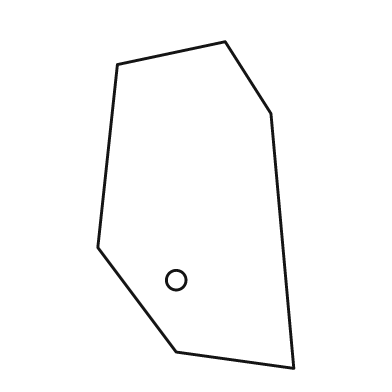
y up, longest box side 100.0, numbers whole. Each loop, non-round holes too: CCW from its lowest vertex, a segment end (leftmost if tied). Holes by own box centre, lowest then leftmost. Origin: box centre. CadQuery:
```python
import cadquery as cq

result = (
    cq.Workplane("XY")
    .moveTo(30.0, -50.0)
    .lineTo(23.0, 28.0)
    .lineTo(9.0, 50.0)
    .lineTo(-24.0, 43.0)
    .lineTo(-30.0, -13.0)
    .lineTo(-6.0, -45.0)
    .close()
    .moveTo(-6.0, -23.0)
    .circle(3.0)
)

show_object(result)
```